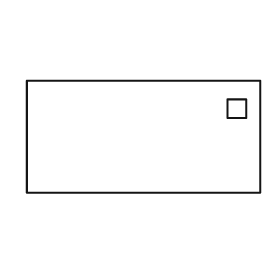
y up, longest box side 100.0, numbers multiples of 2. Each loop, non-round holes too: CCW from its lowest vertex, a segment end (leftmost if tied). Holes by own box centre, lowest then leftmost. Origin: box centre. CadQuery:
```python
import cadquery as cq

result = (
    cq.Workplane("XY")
    .moveTo(-50.0, -24.0)
    .lineTo(50.0, -24.0)
    .lineTo(50.0, 24.0)
    .lineTo(-50.0, 24.0)
    .close()
    .moveTo(36.0, 8.0)
    .lineTo(44.0, 8.0)
    .lineTo(44.0, 16.0)
    .lineTo(36.0, 16.0)
    .close()
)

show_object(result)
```